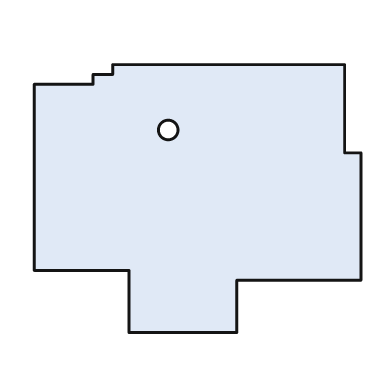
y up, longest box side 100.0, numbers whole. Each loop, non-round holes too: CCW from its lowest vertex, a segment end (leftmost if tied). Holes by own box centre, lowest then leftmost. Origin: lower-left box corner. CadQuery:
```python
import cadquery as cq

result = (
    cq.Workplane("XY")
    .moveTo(29.0, 0.0)
    .lineTo(62.0, 0.0)
    .lineTo(62.0, 16.0)
    .lineTo(100.0, 16.0)
    .lineTo(100.0, 55.0)
    .lineTo(95.0, 55.0)
    .lineTo(95.0, 82.0)
    .lineTo(24.0, 82.0)
    .lineTo(24.0, 79.0)
    .lineTo(18.0, 79.0)
    .lineTo(18.0, 76.0)
    .lineTo(0.0, 76.0)
    .lineTo(0.0, 19.0)
    .lineTo(29.0, 19.0)
    .close()
    .moveTo(41.0, 62.0)
    .circle(3.0)
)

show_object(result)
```